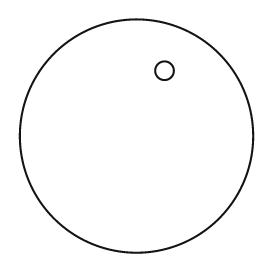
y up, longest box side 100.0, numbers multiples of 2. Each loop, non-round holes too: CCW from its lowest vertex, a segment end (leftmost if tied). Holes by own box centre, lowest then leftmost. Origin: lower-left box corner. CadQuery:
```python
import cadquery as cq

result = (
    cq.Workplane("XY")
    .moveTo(50.0, 50.0)
    .circle(50.0)
    .moveTo(62.0, 78.0)
    .circle(4.0)
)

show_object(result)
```